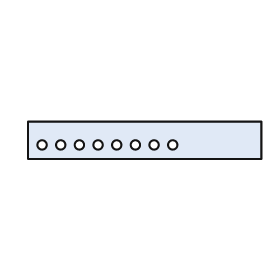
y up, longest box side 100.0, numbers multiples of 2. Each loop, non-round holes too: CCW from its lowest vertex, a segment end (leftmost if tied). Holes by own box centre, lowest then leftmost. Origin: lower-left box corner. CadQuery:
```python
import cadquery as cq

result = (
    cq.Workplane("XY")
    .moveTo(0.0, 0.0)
    .lineTo(100.0, 0.0)
    .lineTo(100.0, 16.0)
    .lineTo(0.0, 16.0)
    .close()
    .moveTo(6.0, 6.0)
    .circle(2.0)
    .moveTo(14.0, 6.0)
    .circle(2.0)
    .moveTo(22.0, 6.0)
    .circle(2.0)
    .moveTo(30.0, 6.0)
    .circle(2.0)
    .moveTo(38.0, 6.0)
    .circle(2.0)
    .moveTo(46.0, 6.0)
    .circle(2.0)
    .moveTo(54.0, 6.0)
    .circle(2.0)
    .moveTo(62.0, 6.0)
    .circle(2.0)
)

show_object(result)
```